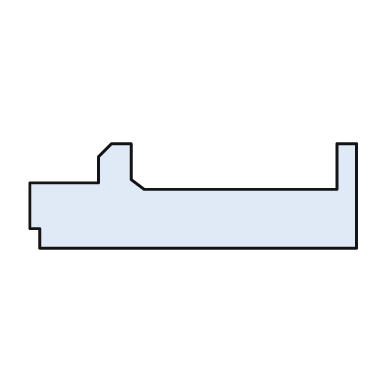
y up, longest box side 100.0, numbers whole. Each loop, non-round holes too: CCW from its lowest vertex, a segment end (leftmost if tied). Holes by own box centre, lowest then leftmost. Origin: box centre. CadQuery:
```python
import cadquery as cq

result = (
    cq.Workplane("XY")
    .moveTo(-47.0, -16.0)
    .lineTo(50.0, -16.0)
    .lineTo(50.0, 16.0)
    .lineTo(44.0, 16.0)
    .lineTo(44.0, 2.0)
    .lineTo(-15.0, 2.0)
    .lineTo(-19.0, 5.0)
    .lineTo(-19.0, 16.0)
    .lineTo(-25.0, 16.0)
    .lineTo(-29.0, 12.0)
    .lineTo(-29.0, 4.0)
    .lineTo(-50.0, 4.0)
    .lineTo(-50.0, -10.0)
    .lineTo(-47.0, -10.0)
    .close()
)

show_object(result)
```